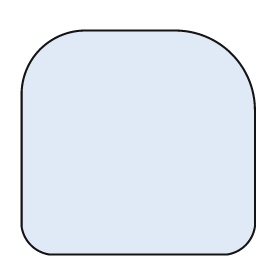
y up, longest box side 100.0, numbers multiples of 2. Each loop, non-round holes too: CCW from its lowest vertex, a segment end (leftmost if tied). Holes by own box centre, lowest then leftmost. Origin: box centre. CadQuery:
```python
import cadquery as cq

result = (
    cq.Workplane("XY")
    .moveTo(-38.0, -48.0)
    .lineTo(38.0, -48.0)
    .threePointArc((46.0, -44.0), (50.0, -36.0))
    .lineTo(50.0, 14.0)
    .threePointArc((40.0, 38.0), (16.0, 48.0))
    .lineTo(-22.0, 48.0)
    .threePointArc((-42.0, 40.0), (-50.0, 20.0))
    .lineTo(-50.0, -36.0)
    .threePointArc((-46.0, -44.0), (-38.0, -48.0))
    .close()
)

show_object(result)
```